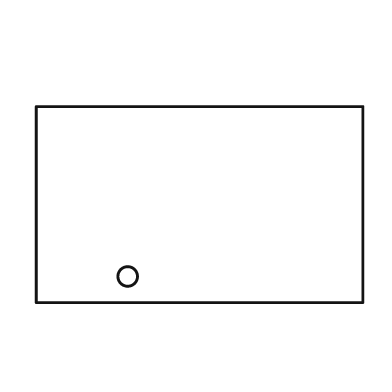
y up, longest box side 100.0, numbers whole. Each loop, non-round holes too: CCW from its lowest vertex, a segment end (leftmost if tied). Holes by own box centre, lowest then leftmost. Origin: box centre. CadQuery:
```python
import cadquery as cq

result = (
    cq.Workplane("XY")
    .moveTo(-50.0, -30.0)
    .lineTo(50.0, -30.0)
    .lineTo(50.0, 30.0)
    .lineTo(-50.0, 30.0)
    .close()
    .moveTo(-22.0, -22.0)
    .circle(3.0)
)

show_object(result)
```